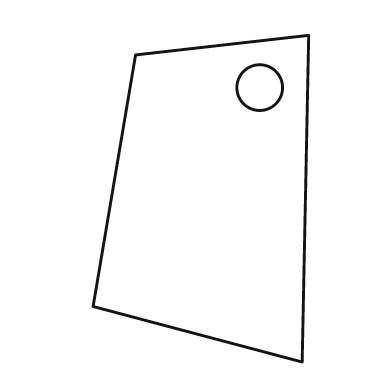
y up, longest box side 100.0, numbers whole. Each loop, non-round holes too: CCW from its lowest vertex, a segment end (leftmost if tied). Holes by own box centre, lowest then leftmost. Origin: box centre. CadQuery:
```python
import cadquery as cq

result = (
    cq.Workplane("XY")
    .moveTo(31.0, -50.0)
    .lineTo(33.0, 50.0)
    .lineTo(-20.0, 44.0)
    .lineTo(-33.0, -33.0)
    .close()
    .moveTo(18.0, 34.0)
    .circle(7.0)
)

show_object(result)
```